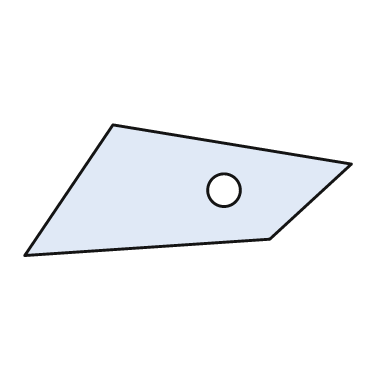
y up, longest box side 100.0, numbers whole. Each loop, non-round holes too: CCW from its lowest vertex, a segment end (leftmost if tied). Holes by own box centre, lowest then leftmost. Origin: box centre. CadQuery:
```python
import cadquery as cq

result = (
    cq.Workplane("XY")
    .moveTo(-50.0, -20.0)
    .lineTo(25.0, -15.0)
    .lineTo(50.0, 8.0)
    .lineTo(-23.0, 20.0)
    .close()
    .moveTo(11.0, 0.0)
    .circle(5.0)
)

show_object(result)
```